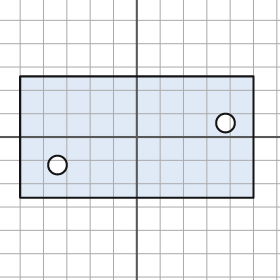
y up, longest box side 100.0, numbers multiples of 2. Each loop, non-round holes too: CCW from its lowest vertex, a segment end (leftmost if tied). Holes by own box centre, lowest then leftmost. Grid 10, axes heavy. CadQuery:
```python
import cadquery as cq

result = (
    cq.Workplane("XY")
    .moveTo(-50.0, -26.0)
    .lineTo(50.0, -26.0)
    .lineTo(50.0, 26.0)
    .lineTo(-50.0, 26.0)
    .close()
    .moveTo(-34.0, -12.0)
    .circle(4.0)
    .moveTo(38.0, 6.0)
    .circle(4.0)
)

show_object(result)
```